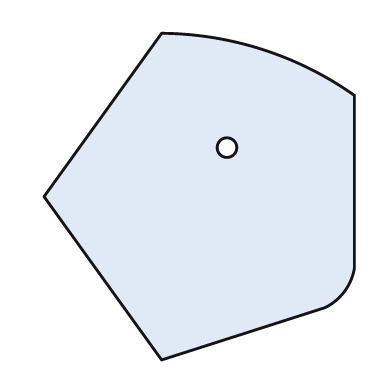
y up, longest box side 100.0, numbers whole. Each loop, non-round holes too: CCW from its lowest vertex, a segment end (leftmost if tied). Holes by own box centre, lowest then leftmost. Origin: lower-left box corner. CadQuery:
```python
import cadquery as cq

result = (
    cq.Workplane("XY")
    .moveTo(36.0, 0.0)
    .lineTo(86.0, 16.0)
    .threePointArc((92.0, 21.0), (95.0, 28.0))
    .lineTo(95.0, 81.0)
    .threePointArc((67.0, 95.0), (36.0, 100.0))
    .lineTo(0.0, 50.0)
    .close()
    .moveTo(56.0, 65.0)
    .circle(3.0)
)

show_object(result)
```